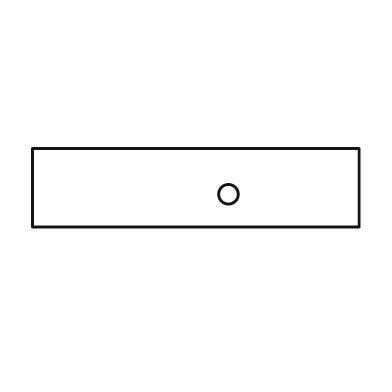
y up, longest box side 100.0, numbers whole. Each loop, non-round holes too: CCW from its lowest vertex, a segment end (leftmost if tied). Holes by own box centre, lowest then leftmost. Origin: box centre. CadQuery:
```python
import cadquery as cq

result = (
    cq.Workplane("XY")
    .moveTo(-50.0, -12.0)
    .lineTo(50.0, -12.0)
    .lineTo(50.0, 12.0)
    .lineTo(-50.0, 12.0)
    .close()
    .moveTo(10.0, -2.0)
    .circle(3.0)
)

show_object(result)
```